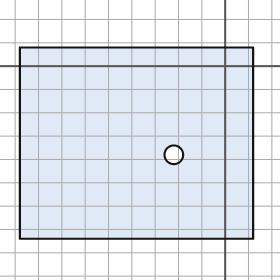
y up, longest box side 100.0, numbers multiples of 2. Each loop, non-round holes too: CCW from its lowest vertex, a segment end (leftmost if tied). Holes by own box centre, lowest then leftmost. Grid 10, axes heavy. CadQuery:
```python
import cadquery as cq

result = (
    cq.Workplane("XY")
    .moveTo(-88.0, -74.0)
    .lineTo(12.0, -74.0)
    .lineTo(12.0, 8.0)
    .lineTo(-88.0, 8.0)
    .close()
    .moveTo(-22.0, -38.0)
    .circle(4.0)
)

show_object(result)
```